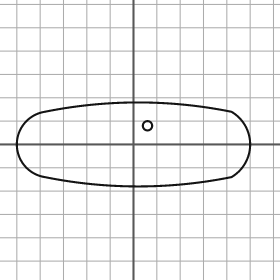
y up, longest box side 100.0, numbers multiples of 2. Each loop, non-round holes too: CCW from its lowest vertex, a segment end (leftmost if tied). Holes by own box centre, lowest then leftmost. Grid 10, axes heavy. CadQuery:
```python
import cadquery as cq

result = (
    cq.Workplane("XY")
    .moveTo(-38.0, -14.0)
    .threePointArc((2.0, -18.0), (42.0, -14.0))
    .threePointArc((50.0, 0.0), (42.0, 14.0))
    .threePointArc((2.0, 18.0), (-38.0, 14.0))
    .threePointArc((-50.0, 0.0), (-38.0, -14.0))
    .close()
    .moveTo(6.0, 8.0)
    .circle(2.0)
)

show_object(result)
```